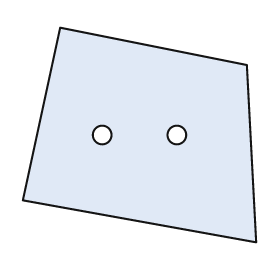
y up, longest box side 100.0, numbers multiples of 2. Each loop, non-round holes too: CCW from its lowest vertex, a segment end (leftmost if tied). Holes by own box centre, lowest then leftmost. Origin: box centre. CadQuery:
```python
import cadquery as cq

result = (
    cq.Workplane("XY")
    .moveTo(50.0, -46.0)
    .lineTo(46.0, 30.0)
    .lineTo(-34.0, 46.0)
    .lineTo(-50.0, -28.0)
    .close()
    .moveTo(-16.0, 0.0)
    .circle(4.0)
    .moveTo(16.0, 0.0)
    .circle(4.0)
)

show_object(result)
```